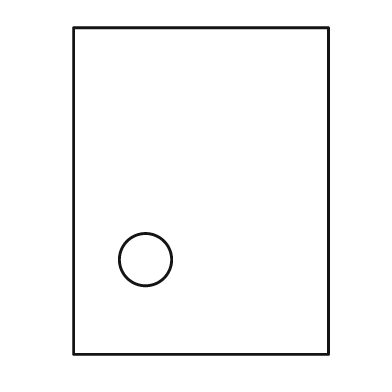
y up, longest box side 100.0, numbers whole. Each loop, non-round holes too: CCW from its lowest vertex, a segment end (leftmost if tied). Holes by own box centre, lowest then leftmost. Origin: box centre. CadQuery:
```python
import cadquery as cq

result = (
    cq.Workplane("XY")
    .moveTo(-39.0, -50.0)
    .lineTo(39.0, -50.0)
    .lineTo(39.0, 50.0)
    .lineTo(-39.0, 50.0)
    .close()
    .moveTo(-17.0, -21.0)
    .circle(8.0)
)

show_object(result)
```